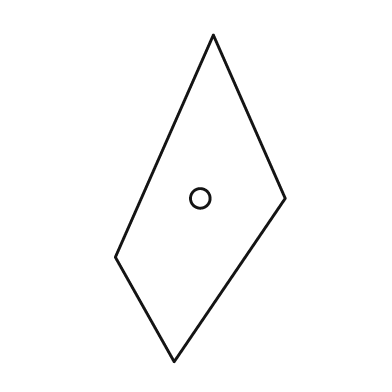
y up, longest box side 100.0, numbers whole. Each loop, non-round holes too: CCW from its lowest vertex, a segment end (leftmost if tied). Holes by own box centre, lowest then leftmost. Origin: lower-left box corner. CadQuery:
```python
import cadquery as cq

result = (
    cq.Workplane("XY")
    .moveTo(18.0, 0.0)
    .lineTo(52.0, 50.0)
    .lineTo(30.0, 100.0)
    .lineTo(0.0, 32.0)
    .close()
    .moveTo(26.0, 50.0)
    .circle(3.0)
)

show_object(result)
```